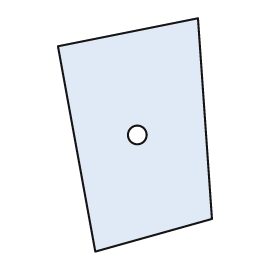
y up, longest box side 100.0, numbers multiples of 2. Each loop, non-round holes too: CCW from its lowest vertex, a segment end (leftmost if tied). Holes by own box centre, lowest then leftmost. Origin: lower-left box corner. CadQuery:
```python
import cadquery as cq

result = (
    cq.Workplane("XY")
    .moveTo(16.0, 0.0)
    .lineTo(66.0, 14.0)
    .lineTo(60.0, 100.0)
    .lineTo(0.0, 88.0)
    .close()
    .moveTo(34.0, 50.0)
    .circle(4.0)
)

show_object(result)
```